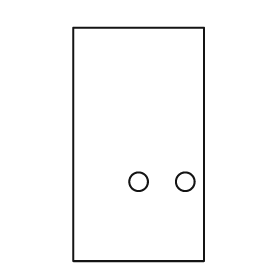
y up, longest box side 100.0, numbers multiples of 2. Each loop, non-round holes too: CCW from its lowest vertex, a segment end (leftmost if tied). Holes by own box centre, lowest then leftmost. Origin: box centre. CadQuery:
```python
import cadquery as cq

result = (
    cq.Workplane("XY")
    .moveTo(-28.0, -50.0)
    .lineTo(28.0, -50.0)
    .lineTo(28.0, 50.0)
    .lineTo(-28.0, 50.0)
    .close()
    .moveTo(0.0, -16.0)
    .circle(4.0)
    .moveTo(20.0, -16.0)
    .circle(4.0)
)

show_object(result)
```